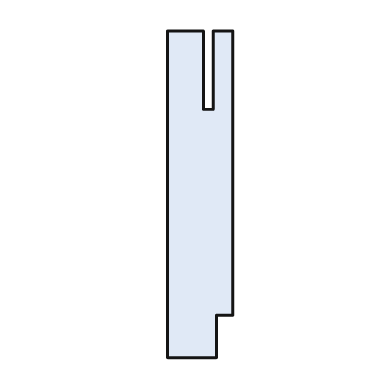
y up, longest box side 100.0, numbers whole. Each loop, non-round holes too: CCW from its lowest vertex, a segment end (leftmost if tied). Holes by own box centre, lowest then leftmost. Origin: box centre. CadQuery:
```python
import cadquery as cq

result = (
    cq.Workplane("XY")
    .moveTo(-10.0, -50.0)
    .lineTo(5.0, -50.0)
    .lineTo(5.0, -37.0)
    .lineTo(10.0, -37.0)
    .lineTo(10.0, 50.0)
    .lineTo(4.0, 50.0)
    .lineTo(4.0, 26.0)
    .lineTo(1.0, 26.0)
    .lineTo(1.0, 50.0)
    .lineTo(-10.0, 50.0)
    .close()
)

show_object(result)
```